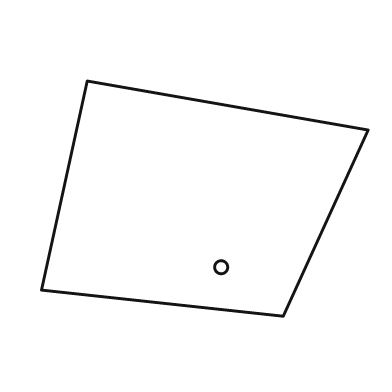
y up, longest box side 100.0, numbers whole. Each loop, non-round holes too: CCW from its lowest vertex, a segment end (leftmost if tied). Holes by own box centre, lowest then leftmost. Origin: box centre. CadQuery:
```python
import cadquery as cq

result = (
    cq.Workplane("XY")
    .moveTo(24.0, -36.0)
    .lineTo(50.0, 21.0)
    .lineTo(-36.0, 36.0)
    .lineTo(-50.0, -28.0)
    .close()
    .moveTo(5.0, -21.0)
    .circle(2.0)
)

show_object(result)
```